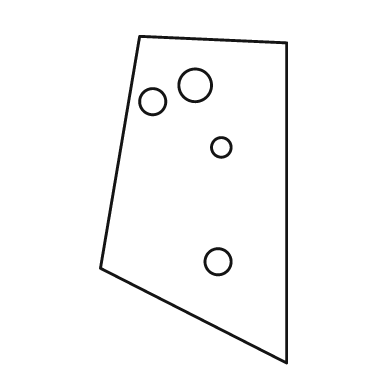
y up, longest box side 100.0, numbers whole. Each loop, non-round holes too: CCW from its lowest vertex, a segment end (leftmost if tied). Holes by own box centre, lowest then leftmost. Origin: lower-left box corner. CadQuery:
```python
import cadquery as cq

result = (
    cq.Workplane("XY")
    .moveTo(57.0, 0.0)
    .lineTo(57.0, 98.0)
    .lineTo(12.0, 100.0)
    .lineTo(0.0, 29.0)
    .close()
    .moveTo(36.0, 31.0)
    .circle(4.0)
    .moveTo(37.0, 66.0)
    .circle(3.0)
    .moveTo(16.0, 80.0)
    .circle(4.0)
    .moveTo(29.0, 85.0)
    .circle(5.0)
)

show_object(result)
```